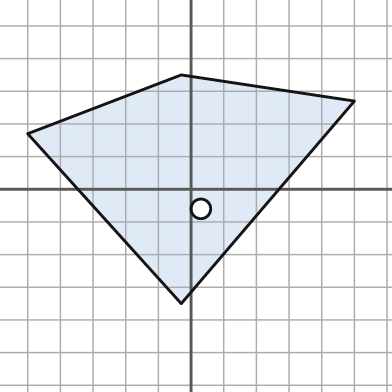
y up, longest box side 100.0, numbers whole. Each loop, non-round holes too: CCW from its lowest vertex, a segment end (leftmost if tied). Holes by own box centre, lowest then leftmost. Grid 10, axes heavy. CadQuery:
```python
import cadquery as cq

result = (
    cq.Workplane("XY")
    .moveTo(-3.0, -35.0)
    .lineTo(50.0, 27.0)
    .lineTo(-3.0, 35.0)
    .lineTo(-50.0, 17.0)
    .close()
    .moveTo(3.0, -6.0)
    .circle(3.0)
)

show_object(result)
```